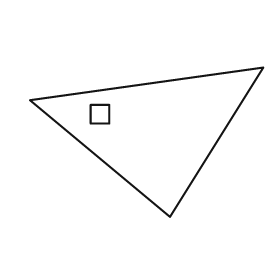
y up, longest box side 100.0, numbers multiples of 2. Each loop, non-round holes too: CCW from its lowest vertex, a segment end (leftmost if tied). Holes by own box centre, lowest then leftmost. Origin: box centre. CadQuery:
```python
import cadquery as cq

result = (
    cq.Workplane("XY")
    .moveTo(10.0, -32.0)
    .lineTo(50.0, 32.0)
    .lineTo(-50.0, 18.0)
    .close()
    .moveTo(-24.0, 8.0)
    .lineTo(-16.0, 8.0)
    .lineTo(-16.0, 16.0)
    .lineTo(-24.0, 16.0)
    .close()
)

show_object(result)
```